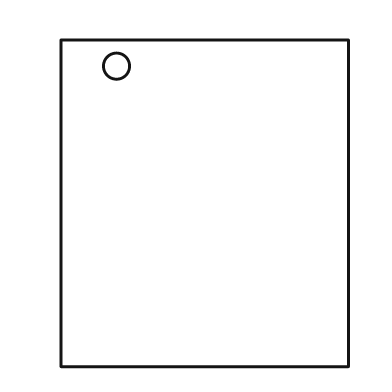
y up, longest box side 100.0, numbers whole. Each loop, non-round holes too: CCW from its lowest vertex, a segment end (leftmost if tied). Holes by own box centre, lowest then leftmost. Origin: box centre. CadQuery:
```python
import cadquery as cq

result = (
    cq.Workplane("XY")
    .moveTo(-44.0, -50.0)
    .lineTo(44.0, -50.0)
    .lineTo(44.0, 50.0)
    .lineTo(-44.0, 50.0)
    .close()
    .moveTo(-27.0, 42.0)
    .circle(4.0)
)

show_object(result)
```